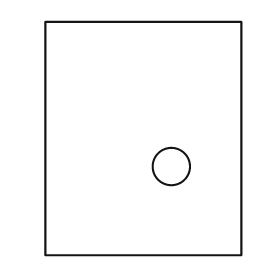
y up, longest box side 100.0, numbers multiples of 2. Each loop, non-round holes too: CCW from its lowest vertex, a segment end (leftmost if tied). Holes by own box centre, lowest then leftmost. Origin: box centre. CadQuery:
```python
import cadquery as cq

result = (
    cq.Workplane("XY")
    .moveTo(-42.0, -50.0)
    .lineTo(42.0, -50.0)
    .lineTo(42.0, 50.0)
    .lineTo(-42.0, 50.0)
    .close()
    .moveTo(12.0, -12.0)
    .circle(8.0)
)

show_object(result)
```